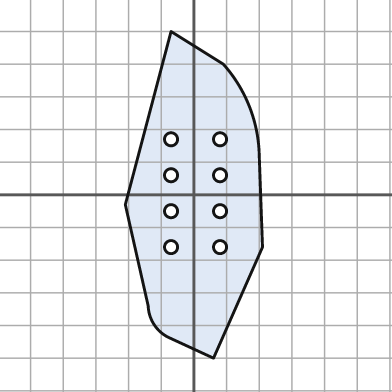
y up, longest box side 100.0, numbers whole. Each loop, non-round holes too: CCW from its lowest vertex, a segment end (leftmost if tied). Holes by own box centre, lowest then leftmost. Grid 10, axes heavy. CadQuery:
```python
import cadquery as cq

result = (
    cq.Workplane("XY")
    .moveTo(6.0, -50.0)
    .lineTo(21.0, -16.0)
    .lineTo(20.0, 12.0)
    .threePointArc((17.0, 27.0), (9.0, 40.0))
    .lineTo(-7.0, 50.0)
    .lineTo(-21.0, -3.0)
    .lineTo(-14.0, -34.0)
    .threePointArc((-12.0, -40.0), (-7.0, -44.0))
    .close()
    .moveTo(-7.0, -16.0)
    .circle(2.0)
    .moveTo(8.0, -16.0)
    .circle(2.0)
    .moveTo(-7.0, -5.0)
    .circle(2.0)
    .moveTo(8.0, -5.0)
    .circle(2.0)
    .moveTo(-7.0, 6.0)
    .circle(2.0)
    .moveTo(8.0, 6.0)
    .circle(2.0)
    .moveTo(-7.0, 17.0)
    .circle(2.0)
    .moveTo(8.0, 17.0)
    .circle(2.0)
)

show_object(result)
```